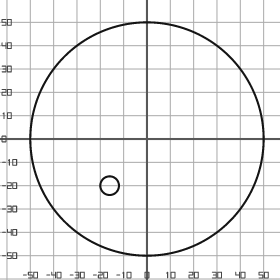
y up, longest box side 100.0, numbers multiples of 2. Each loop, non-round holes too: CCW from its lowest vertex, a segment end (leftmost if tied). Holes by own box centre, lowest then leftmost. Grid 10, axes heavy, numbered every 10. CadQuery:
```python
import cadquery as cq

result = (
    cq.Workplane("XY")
    .moveTo(0.0, 0.0)
    .circle(50.0)
    .moveTo(-16.0, -20.0)
    .circle(4.0)
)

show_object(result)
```